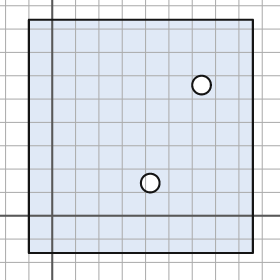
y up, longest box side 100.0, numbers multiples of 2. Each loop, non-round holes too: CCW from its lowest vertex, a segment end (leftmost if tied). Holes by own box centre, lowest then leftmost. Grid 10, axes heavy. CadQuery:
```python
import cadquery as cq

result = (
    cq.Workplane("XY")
    .moveTo(-10.0, -16.0)
    .lineTo(86.0, -16.0)
    .lineTo(86.0, 84.0)
    .lineTo(-10.0, 84.0)
    .close()
    .moveTo(42.0, 14.0)
    .circle(4.0)
    .moveTo(64.0, 56.0)
    .circle(4.0)
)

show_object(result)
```